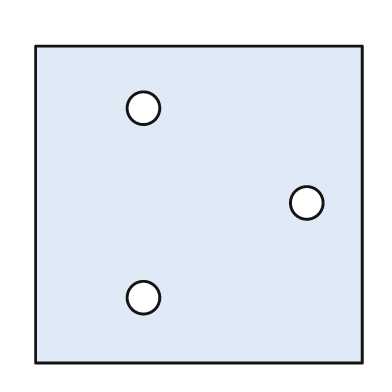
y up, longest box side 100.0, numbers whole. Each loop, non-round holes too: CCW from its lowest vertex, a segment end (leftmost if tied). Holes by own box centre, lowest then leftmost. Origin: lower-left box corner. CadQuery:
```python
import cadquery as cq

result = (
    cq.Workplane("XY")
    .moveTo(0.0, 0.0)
    .lineTo(100.0, 0.0)
    .lineTo(100.0, 97.0)
    .lineTo(0.0, 97.0)
    .close()
    .moveTo(33.0, 20.0)
    .circle(5.0)
    .moveTo(83.0, 49.0)
    .circle(5.0)
    .moveTo(33.0, 78.0)
    .circle(5.0)
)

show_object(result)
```